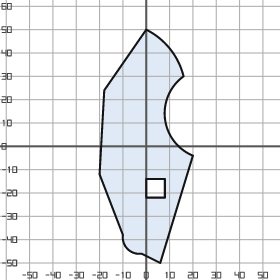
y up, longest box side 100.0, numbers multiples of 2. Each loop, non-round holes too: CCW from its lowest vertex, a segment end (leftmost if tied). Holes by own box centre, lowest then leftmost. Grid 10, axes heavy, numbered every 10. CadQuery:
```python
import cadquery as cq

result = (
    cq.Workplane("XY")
    .moveTo(6.0, -50.0)
    .lineTo(20.0, -4.0)
    .threePointArc((8.0, 12.0), (16.0, 30.0))
    .threePointArc((10.0, 42.0), (0.0, 50.0))
    .lineTo(-18.0, 24.0)
    .lineTo(-20.0, -12.0)
    .lineTo(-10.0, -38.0)
    .threePointArc((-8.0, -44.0), (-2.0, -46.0))
    .close()
    .moveTo(0.0, -22.0)
    .lineTo(8.0, -22.0)
    .lineTo(8.0, -14.0)
    .lineTo(0.0, -14.0)
    .close()
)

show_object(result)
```